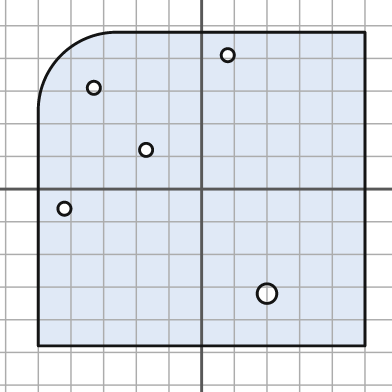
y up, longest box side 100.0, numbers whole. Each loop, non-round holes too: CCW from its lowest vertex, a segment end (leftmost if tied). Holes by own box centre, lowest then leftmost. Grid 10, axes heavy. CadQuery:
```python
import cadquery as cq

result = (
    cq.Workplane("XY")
    .moveTo(-50.0, -48.0)
    .lineTo(50.0, -48.0)
    .lineTo(50.0, 48.0)
    .lineTo(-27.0, 48.0)
    .threePointArc((-43.0, 41.0), (-50.0, 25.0))
    .close()
    .moveTo(20.0, -32.0)
    .circle(3.0)
    .moveTo(-42.0, -6.0)
    .circle(2.0)
    .moveTo(-17.0, 12.0)
    .circle(2.0)
    .moveTo(-33.0, 31.0)
    .circle(2.0)
    .moveTo(8.0, 41.0)
    .circle(2.0)
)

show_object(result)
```